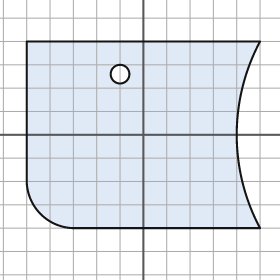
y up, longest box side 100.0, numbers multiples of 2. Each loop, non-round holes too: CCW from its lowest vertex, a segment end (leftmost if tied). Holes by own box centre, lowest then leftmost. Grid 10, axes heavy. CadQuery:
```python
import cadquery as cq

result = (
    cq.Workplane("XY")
    .moveTo(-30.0, -40.0)
    .lineTo(50.0, -40.0)
    .threePointArc((40.0, 0.0), (50.0, 40.0))
    .lineTo(-50.0, 40.0)
    .lineTo(-50.0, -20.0)
    .threePointArc((-44.0, -34.0), (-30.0, -40.0))
    .close()
    .moveTo(-10.0, 26.0)
    .circle(4.0)
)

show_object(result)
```